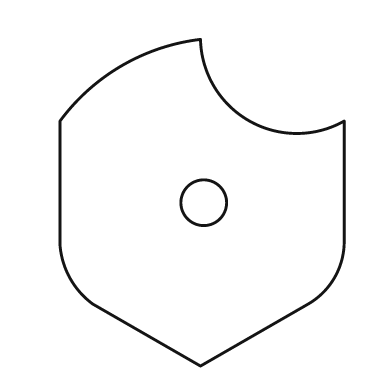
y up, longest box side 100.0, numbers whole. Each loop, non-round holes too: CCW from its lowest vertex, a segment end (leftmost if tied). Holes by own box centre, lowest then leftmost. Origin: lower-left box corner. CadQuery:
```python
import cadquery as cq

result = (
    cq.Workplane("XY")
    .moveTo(43.0, 0.0)
    .lineTo(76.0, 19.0)
    .threePointArc((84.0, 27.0), (87.0, 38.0))
    .lineTo(87.0, 75.0)
    .threePointArc((58.0, 75.0), (43.0, 100.0))
    .threePointArc((19.0, 92.0), (0.0, 75.0))
    .lineTo(0.0, 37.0)
    .threePointArc((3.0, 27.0), (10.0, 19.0))
    .close()
    .moveTo(44.0, 50.0)
    .circle(7.0)
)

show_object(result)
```